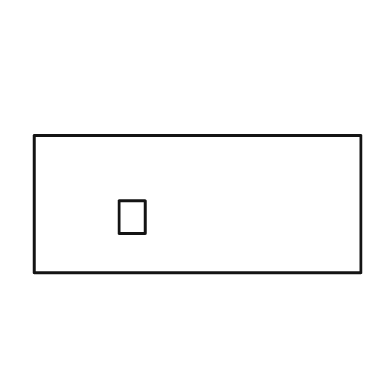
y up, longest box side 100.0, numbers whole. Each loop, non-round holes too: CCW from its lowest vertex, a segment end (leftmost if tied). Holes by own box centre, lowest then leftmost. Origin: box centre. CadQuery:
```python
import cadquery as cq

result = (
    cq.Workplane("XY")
    .moveTo(-50.0, -21.0)
    .lineTo(50.0, -21.0)
    .lineTo(50.0, 21.0)
    .lineTo(-50.0, 21.0)
    .close()
    .moveTo(-24.0, -9.0)
    .lineTo(-16.0, -9.0)
    .lineTo(-16.0, 1.0)
    .lineTo(-24.0, 1.0)
    .close()
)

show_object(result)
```